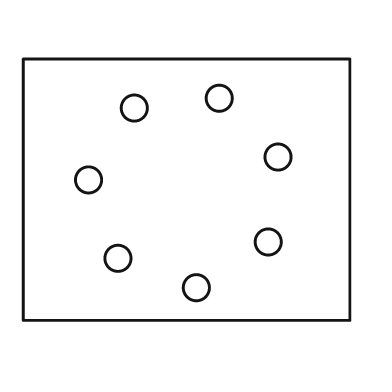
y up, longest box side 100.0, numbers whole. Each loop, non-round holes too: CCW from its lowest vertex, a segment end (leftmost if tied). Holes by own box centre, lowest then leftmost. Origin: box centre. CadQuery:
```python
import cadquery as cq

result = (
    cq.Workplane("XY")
    .moveTo(-50.0, -40.0)
    .lineTo(50.0, -40.0)
    .lineTo(50.0, 40.0)
    .lineTo(-50.0, 40.0)
    .close()
    .moveTo(3.0, -30.0)
    .circle(4.0)
    .moveTo(-21.0, -21.0)
    .circle(4.0)
    .moveTo(25.0, -16.0)
    .circle(4.0)
    .moveTo(-30.0, 3.0)
    .circle(4.0)
    .moveTo(28.0, 10.0)
    .circle(4.0)
    .moveTo(-16.0, 25.0)
    .circle(4.0)
    .moveTo(10.0, 28.0)
    .circle(4.0)
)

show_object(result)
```